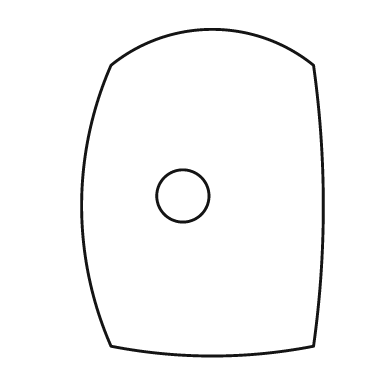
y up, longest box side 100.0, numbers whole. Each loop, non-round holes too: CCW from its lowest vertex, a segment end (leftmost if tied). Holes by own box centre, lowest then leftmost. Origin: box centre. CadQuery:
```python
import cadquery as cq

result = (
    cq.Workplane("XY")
    .moveTo(-28.0, -47.0)
    .threePointArc((3.0, -50.0), (34.0, -47.0))
    .threePointArc((37.0, -4.0), (34.0, 39.0))
    .threePointArc((3.0, 50.0), (-28.0, 39.0))
    .threePointArc((-37.0, -4.0), (-28.0, -47.0))
    .close()
    .moveTo(-6.0, -1.0)
    .circle(8.0)
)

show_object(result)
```